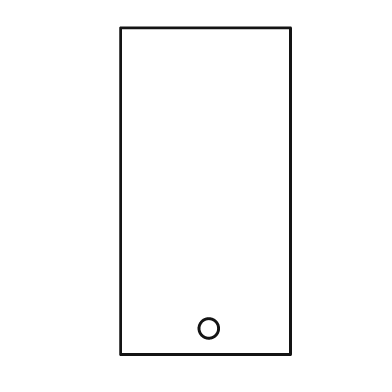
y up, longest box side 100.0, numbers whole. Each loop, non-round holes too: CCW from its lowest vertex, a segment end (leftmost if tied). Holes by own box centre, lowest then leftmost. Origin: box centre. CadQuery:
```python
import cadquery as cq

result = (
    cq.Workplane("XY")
    .moveTo(-26.0, -50.0)
    .lineTo(26.0, -50.0)
    .lineTo(26.0, 50.0)
    .lineTo(-26.0, 50.0)
    .close()
    .moveTo(1.0, -42.0)
    .circle(3.0)
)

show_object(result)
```